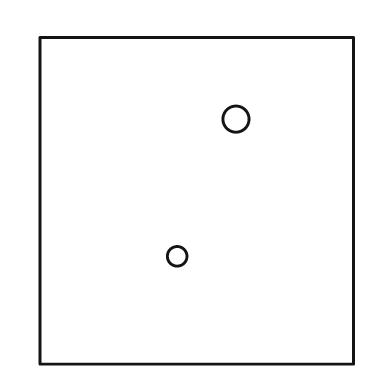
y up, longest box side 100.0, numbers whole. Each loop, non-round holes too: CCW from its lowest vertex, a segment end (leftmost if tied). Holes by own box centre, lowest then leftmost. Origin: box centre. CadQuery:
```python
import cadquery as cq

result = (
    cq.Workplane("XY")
    .moveTo(-48.0, -50.0)
    .lineTo(48.0, -50.0)
    .lineTo(48.0, 50.0)
    .lineTo(-48.0, 50.0)
    .close()
    .moveTo(-6.0, -17.0)
    .circle(3.0)
    .moveTo(12.0, 25.0)
    .circle(4.0)
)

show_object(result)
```